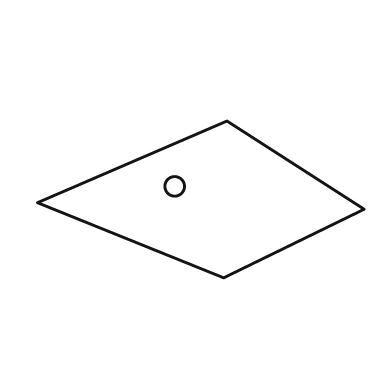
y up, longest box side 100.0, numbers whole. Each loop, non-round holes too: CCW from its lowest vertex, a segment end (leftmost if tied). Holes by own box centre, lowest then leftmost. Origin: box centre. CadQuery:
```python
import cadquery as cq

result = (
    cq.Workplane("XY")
    .moveTo(7.0, -24.0)
    .lineTo(50.0, -3.0)
    .lineTo(8.0, 24.0)
    .lineTo(-50.0, -1.0)
    .close()
    .moveTo(-8.0, 4.0)
    .circle(3.0)
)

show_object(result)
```